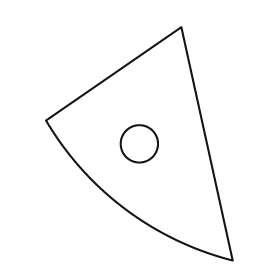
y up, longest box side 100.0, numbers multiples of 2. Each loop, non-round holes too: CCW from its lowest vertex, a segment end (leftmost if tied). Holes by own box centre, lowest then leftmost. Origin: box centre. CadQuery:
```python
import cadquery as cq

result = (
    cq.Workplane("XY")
    .moveTo(40.0, -50.0)
    .lineTo(18.0, 50.0)
    .lineTo(-40.0, 10.0)
    .threePointArc((-6.0, -28.0), (40.0, -50.0))
    .close()
    .moveTo(0.0, 0.0)
    .circle(8.0)
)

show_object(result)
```